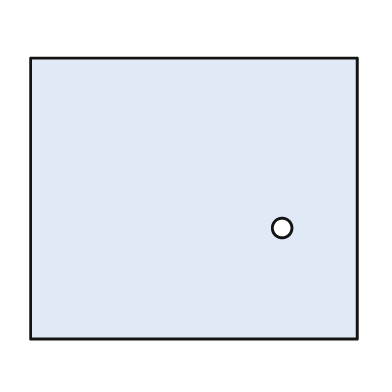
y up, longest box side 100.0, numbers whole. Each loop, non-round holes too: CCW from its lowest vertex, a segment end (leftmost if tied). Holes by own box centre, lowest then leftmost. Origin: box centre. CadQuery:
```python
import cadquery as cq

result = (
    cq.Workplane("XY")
    .moveTo(-50.0, -43.0)
    .lineTo(50.0, -43.0)
    .lineTo(50.0, 43.0)
    .lineTo(-50.0, 43.0)
    .close()
    .moveTo(27.0, -9.0)
    .circle(3.0)
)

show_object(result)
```